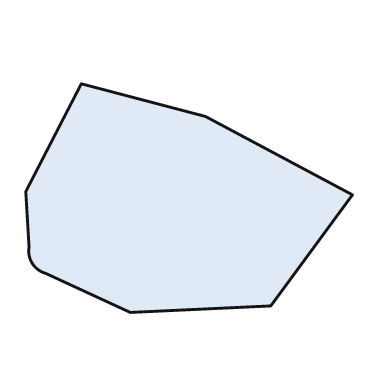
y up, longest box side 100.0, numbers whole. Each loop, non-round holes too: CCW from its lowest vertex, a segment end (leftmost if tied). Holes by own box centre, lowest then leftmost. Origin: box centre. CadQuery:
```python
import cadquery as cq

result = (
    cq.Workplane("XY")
    .moveTo(-18.0, -35.0)
    .lineTo(25.0, -33.0)
    .lineTo(50.0, 1.0)
    .lineTo(5.0, 25.0)
    .lineTo(-33.0, 35.0)
    .lineTo(-50.0, 2.0)
    .lineTo(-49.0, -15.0)
    .threePointArc((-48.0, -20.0), (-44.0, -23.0))
    .close()
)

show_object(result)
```